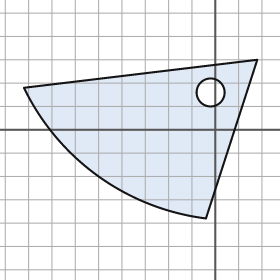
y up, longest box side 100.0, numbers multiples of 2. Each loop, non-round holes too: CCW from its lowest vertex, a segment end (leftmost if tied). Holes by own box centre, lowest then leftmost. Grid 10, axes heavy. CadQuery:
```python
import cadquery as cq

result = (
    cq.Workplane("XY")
    .moveTo(-4.0, -38.0)
    .lineTo(18.0, 30.0)
    .lineTo(-82.0, 18.0)
    .threePointArc((-50.0, -20.0), (-4.0, -38.0))
    .close()
    .moveTo(-2.0, 16.0)
    .circle(6.0)
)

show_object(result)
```